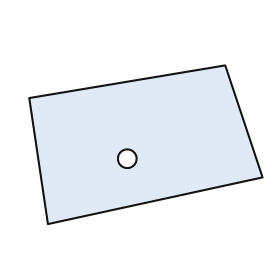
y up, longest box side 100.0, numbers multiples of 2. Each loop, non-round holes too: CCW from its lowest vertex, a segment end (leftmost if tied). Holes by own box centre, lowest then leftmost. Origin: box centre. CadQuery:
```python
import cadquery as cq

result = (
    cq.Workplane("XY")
    .moveTo(-42.0, -34.0)
    .lineTo(50.0, -14.0)
    .lineTo(34.0, 34.0)
    .lineTo(-50.0, 20.0)
    .close()
    .moveTo(-8.0, -6.0)
    .circle(4.0)
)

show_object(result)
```